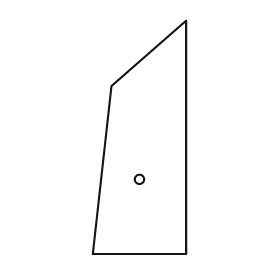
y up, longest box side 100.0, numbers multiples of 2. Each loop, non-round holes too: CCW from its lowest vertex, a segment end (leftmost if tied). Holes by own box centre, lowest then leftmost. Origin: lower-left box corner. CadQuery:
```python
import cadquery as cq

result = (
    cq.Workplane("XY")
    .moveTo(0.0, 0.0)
    .lineTo(40.0, 0.0)
    .lineTo(40.0, 100.0)
    .lineTo(8.0, 72.0)
    .close()
    .moveTo(20.0, 32.0)
    .circle(2.0)
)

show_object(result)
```